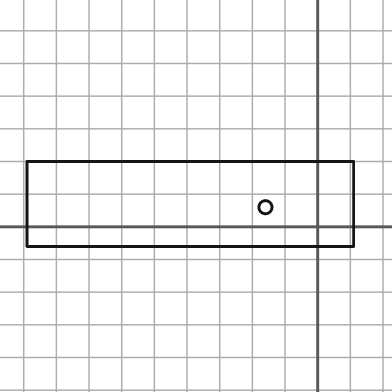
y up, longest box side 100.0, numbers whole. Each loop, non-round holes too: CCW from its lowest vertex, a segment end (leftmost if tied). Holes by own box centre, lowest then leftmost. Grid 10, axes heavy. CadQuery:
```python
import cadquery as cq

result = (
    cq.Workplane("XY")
    .moveTo(-89.0, -6.0)
    .lineTo(11.0, -6.0)
    .lineTo(11.0, 20.0)
    .lineTo(-89.0, 20.0)
    .close()
    .moveTo(-16.0, 6.0)
    .circle(2.0)
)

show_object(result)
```